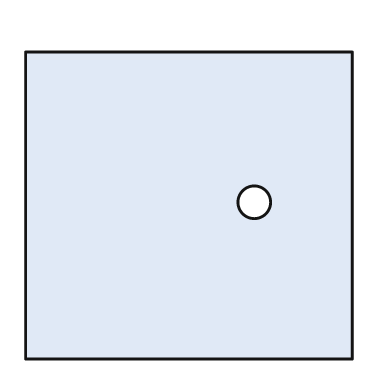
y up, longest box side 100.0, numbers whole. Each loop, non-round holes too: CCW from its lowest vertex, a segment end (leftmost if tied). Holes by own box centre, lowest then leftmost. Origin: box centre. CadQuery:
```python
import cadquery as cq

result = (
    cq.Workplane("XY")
    .moveTo(-50.0, -47.0)
    .lineTo(50.0, -47.0)
    .lineTo(50.0, 47.0)
    .lineTo(-50.0, 47.0)
    .close()
    .moveTo(20.0, 1.0)
    .circle(5.0)
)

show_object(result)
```